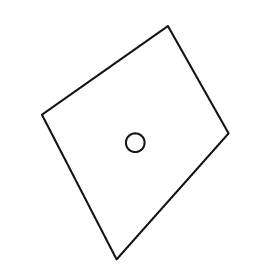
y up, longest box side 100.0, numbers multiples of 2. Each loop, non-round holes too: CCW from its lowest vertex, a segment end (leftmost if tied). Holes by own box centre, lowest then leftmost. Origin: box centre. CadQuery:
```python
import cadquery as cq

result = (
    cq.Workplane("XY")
    .moveTo(-8.0, -50.0)
    .lineTo(40.0, 4.0)
    .lineTo(14.0, 50.0)
    .lineTo(-40.0, 12.0)
    .close()
    .moveTo(0.0, 0.0)
    .circle(4.0)
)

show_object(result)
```